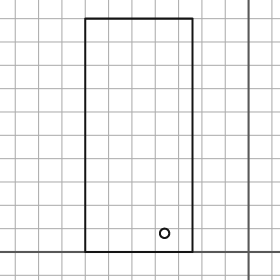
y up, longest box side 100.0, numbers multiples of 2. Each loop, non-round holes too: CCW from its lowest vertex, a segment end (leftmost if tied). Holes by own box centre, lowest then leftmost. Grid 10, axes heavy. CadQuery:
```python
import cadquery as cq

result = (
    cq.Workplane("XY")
    .moveTo(-70.0, 0.0)
    .lineTo(-24.0, 0.0)
    .lineTo(-24.0, 100.0)
    .lineTo(-70.0, 100.0)
    .close()
    .moveTo(-36.0, 8.0)
    .circle(2.0)
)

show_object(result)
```